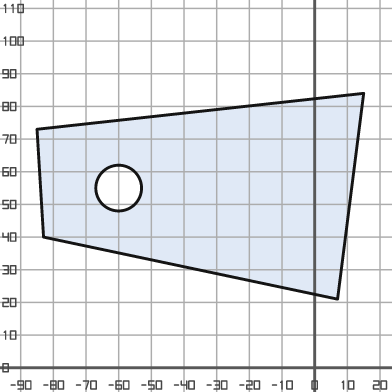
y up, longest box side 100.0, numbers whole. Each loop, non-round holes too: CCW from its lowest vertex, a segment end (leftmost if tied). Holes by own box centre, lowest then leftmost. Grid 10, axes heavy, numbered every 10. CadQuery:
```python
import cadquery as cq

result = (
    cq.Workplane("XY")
    .moveTo(7.0, 21.0)
    .lineTo(15.0, 84.0)
    .lineTo(-85.0, 73.0)
    .lineTo(-83.0, 40.0)
    .close()
    .moveTo(-60.0, 55.0)
    .circle(7.0)
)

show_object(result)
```